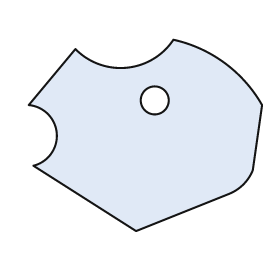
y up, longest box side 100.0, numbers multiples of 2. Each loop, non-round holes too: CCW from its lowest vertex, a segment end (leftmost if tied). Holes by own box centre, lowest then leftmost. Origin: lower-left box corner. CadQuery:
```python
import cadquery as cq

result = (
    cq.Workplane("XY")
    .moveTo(46.0, 0.0)
    .lineTo(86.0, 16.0)
    .threePointArc((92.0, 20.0), (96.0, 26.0))
    .lineTo(100.0, 54.0)
    .threePointArc((84.0, 72.0), (62.0, 82.0))
    .threePointArc((42.0, 70.0), (20.0, 78.0))
    .lineTo(0.0, 54.0)
    .threePointArc((12.0, 42.0), (2.0, 28.0))
    .close()
    .moveTo(54.0, 56.0)
    .circle(6.0)
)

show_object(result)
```